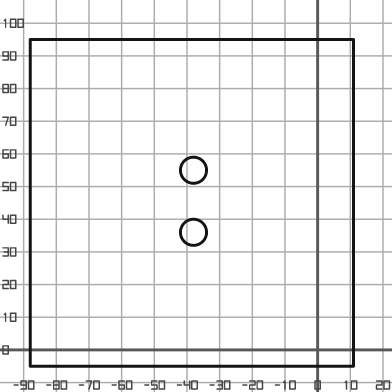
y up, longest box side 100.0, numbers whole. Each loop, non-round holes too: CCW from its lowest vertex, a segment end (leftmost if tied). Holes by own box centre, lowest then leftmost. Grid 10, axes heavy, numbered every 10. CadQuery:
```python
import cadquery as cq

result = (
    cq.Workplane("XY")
    .moveTo(-88.0, -5.0)
    .lineTo(11.0, -5.0)
    .lineTo(11.0, 95.0)
    .lineTo(-88.0, 95.0)
    .close()
    .moveTo(-38.0, 36.0)
    .circle(4.0)
    .moveTo(-38.0, 55.0)
    .circle(4.0)
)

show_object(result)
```